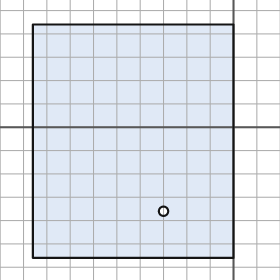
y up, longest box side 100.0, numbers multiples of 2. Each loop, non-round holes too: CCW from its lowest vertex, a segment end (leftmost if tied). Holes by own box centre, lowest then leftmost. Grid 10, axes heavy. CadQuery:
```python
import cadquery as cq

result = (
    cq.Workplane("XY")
    .moveTo(-86.0, -56.0)
    .lineTo(0.0, -56.0)
    .lineTo(0.0, 44.0)
    .lineTo(-86.0, 44.0)
    .close()
    .moveTo(-30.0, -36.0)
    .circle(2.0)
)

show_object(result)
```